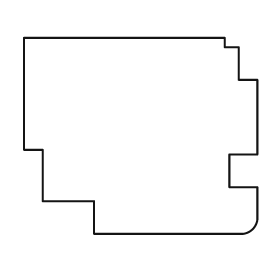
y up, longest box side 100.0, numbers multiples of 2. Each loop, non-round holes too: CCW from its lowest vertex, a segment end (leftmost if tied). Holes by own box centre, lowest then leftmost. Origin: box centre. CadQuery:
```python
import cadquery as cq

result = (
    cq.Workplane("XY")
    .moveTo(-20.0, -42.0)
    .lineTo(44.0, -42.0)
    .threePointArc((48.0, -40.0), (50.0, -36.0))
    .lineTo(50.0, -22.0)
    .lineTo(38.0, -22.0)
    .lineTo(38.0, -8.0)
    .lineTo(50.0, -8.0)
    .lineTo(50.0, 24.0)
    .lineTo(42.0, 24.0)
    .lineTo(42.0, 38.0)
    .lineTo(36.0, 38.0)
    .lineTo(36.0, 42.0)
    .lineTo(-50.0, 42.0)
    .lineTo(-50.0, -6.0)
    .lineTo(-42.0, -6.0)
    .lineTo(-42.0, -28.0)
    .lineTo(-20.0, -28.0)
    .close()
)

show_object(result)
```